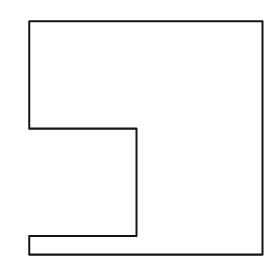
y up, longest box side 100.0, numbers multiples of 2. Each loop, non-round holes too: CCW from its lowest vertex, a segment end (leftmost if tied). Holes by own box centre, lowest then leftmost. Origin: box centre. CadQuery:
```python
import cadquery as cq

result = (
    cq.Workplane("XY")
    .moveTo(-50.0, -50.0)
    .lineTo(50.0, -50.0)
    .lineTo(50.0, 50.0)
    .lineTo(-50.0, 50.0)
    .lineTo(-50.0, 4.0)
    .lineTo(-4.0, 4.0)
    .lineTo(-4.0, -42.0)
    .lineTo(-50.0, -42.0)
    .close()
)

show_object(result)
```